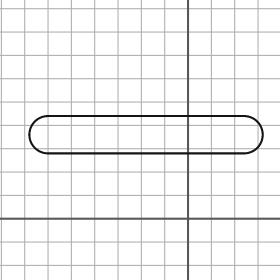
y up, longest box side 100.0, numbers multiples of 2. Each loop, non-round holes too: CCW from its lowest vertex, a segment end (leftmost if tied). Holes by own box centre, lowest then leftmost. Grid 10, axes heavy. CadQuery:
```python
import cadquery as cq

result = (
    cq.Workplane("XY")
    .moveTo(-60.0, 28.0)
    .lineTo(24.0, 28.0)
    .threePointArc((32.0, 36.0), (24.0, 44.0))
    .lineTo(-60.0, 44.0)
    .threePointArc((-68.0, 36.0), (-60.0, 28.0))
    .close()
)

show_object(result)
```